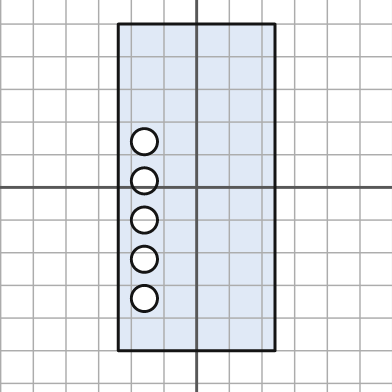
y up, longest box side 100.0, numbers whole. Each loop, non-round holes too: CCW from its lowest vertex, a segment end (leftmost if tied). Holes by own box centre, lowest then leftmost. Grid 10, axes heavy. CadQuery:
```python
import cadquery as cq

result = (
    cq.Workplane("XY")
    .moveTo(-24.0, -50.0)
    .lineTo(24.0, -50.0)
    .lineTo(24.0, 50.0)
    .lineTo(-24.0, 50.0)
    .close()
    .moveTo(-16.0, -34.0)
    .circle(4.0)
    .moveTo(-16.0, -22.0)
    .circle(4.0)
    .moveTo(-16.0, -10.0)
    .circle(4.0)
    .moveTo(-16.0, 2.0)
    .circle(4.0)
    .moveTo(-16.0, 14.0)
    .circle(4.0)
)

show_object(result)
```